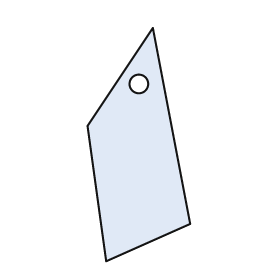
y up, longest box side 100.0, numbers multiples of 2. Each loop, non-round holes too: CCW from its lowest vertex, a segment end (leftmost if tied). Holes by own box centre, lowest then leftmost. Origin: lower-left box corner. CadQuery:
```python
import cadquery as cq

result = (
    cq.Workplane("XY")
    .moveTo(8.0, 0.0)
    .lineTo(44.0, 16.0)
    .lineTo(28.0, 100.0)
    .lineTo(0.0, 58.0)
    .close()
    .moveTo(22.0, 76.0)
    .circle(4.0)
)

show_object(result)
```